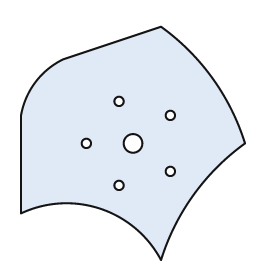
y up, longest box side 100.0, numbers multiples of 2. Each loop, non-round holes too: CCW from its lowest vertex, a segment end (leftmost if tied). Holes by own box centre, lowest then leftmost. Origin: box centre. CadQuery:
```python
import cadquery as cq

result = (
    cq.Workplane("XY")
    .moveTo(12.0, -50.0)
    .threePointArc((26.0, -22.0), (48.0, 0.0))
    .threePointArc((34.0, 28.0), (12.0, 50.0))
    .lineTo(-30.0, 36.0)
    .threePointArc((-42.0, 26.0), (-48.0, 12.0))
    .lineTo(-48.0, -30.0)
    .threePointArc((-14.0, -28.0), (12.0, -50.0))
    .close()
    .moveTo(-6.0, -18.0)
    .circle(2.0)
    .moveTo(16.0, -12.0)
    .circle(2.0)
    .moveTo(-20.0, 0.0)
    .circle(2.0)
    .moveTo(0.0, 0.0)
    .circle(4.0)
    .moveTo(16.0, 12.0)
    .circle(2.0)
    .moveTo(-6.0, 18.0)
    .circle(2.0)
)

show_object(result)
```